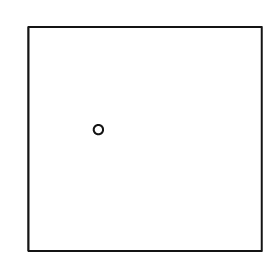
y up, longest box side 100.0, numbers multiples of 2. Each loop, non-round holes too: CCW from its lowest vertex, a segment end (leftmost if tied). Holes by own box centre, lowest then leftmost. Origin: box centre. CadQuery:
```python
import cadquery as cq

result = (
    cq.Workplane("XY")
    .moveTo(-50.0, -48.0)
    .lineTo(50.0, -48.0)
    .lineTo(50.0, 48.0)
    .lineTo(-50.0, 48.0)
    .close()
    .moveTo(-20.0, 4.0)
    .circle(2.0)
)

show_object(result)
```